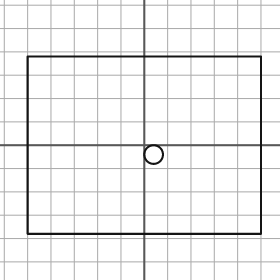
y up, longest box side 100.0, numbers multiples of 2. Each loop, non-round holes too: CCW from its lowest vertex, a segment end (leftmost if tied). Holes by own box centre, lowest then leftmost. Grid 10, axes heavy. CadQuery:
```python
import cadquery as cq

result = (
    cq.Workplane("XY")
    .moveTo(-50.0, -38.0)
    .lineTo(50.0, -38.0)
    .lineTo(50.0, 38.0)
    .lineTo(-50.0, 38.0)
    .close()
    .moveTo(4.0, -4.0)
    .circle(4.0)
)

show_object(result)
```